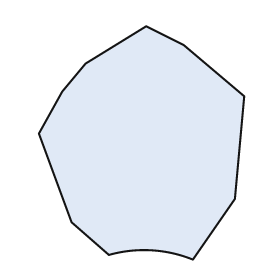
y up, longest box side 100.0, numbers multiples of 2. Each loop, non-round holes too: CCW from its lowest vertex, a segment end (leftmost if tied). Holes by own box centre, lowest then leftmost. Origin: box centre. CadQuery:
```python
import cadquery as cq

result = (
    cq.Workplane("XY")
    .moveTo(22.0, -50.0)
    .lineTo(40.0, -24.0)
    .lineTo(44.0, 20.0)
    .lineTo(18.0, 42.0)
    .lineTo(2.0, 50.0)
    .lineTo(-24.0, 34.0)
    .lineTo(-34.0, 22.0)
    .lineTo(-44.0, 4.0)
    .lineTo(-30.0, -34.0)
    .lineTo(-14.0, -48.0)
    .threePointArc((4.0, -46.0), (22.0, -50.0))
    .close()
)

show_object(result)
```